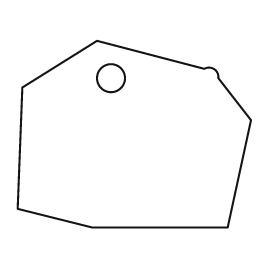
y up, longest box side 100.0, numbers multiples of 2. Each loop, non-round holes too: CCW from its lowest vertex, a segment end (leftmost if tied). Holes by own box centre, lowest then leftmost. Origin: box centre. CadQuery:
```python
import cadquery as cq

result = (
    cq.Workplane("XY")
    .moveTo(-18.0, -40.0)
    .lineTo(40.0, -40.0)
    .lineTo(50.0, 6.0)
    .lineTo(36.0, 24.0)
    .threePointArc((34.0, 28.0), (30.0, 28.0))
    .lineTo(-16.0, 40.0)
    .lineTo(-48.0, 20.0)
    .lineTo(-50.0, -32.0)
    .close()
    .moveTo(-10.0, 24.0)
    .circle(6.0)
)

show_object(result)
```